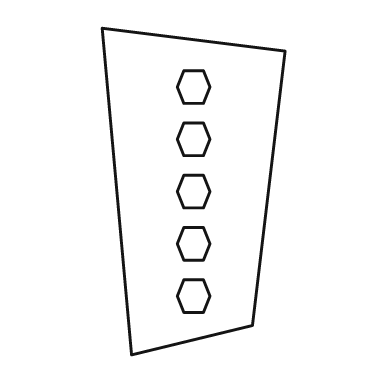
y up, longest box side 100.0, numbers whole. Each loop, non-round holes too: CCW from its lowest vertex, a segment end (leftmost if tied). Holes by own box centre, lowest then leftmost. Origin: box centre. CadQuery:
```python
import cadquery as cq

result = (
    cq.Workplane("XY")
    .moveTo(-19.0, -50.0)
    .lineTo(18.0, -41.0)
    .lineTo(28.0, 43.0)
    .lineTo(-28.0, 50.0)
    .close()
    .moveTo(-3.0, -37.0)
    .lineTo(3.0, -37.0)
    .lineTo(5.0, -32.0)
    .lineTo(3.0, -27.0)
    .lineTo(-3.0, -27.0)
    .lineTo(-5.0, -32.0)
    .close()
    .moveTo(-3.0, -21.0)
    .lineTo(3.0, -21.0)
    .lineTo(5.0, -16.0)
    .lineTo(3.0, -11.0)
    .lineTo(-3.0, -11.0)
    .lineTo(-5.0, -16.0)
    .close()
    .moveTo(-3.0, -5.0)
    .lineTo(3.0, -5.0)
    .lineTo(5.0, 0.0)
    .lineTo(3.0, 5.0)
    .lineTo(-3.0, 5.0)
    .lineTo(-5.0, 0.0)
    .close()
    .moveTo(-3.0, 11.0)
    .lineTo(3.0, 11.0)
    .lineTo(5.0, 16.0)
    .lineTo(3.0, 21.0)
    .lineTo(-3.0, 21.0)
    .lineTo(-5.0, 16.0)
    .close()
    .moveTo(-3.0, 27.0)
    .lineTo(3.0, 27.0)
    .lineTo(5.0, 32.0)
    .lineTo(3.0, 37.0)
    .lineTo(-3.0, 37.0)
    .lineTo(-5.0, 32.0)
    .close()
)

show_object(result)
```